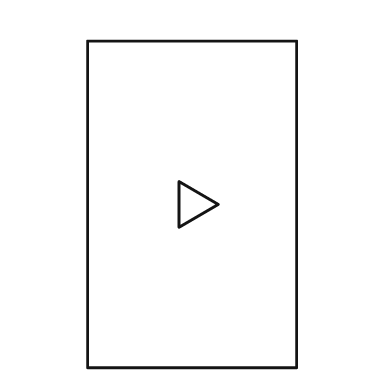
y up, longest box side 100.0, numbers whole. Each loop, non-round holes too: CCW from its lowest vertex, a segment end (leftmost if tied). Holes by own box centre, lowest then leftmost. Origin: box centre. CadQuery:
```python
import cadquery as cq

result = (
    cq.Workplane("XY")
    .moveTo(-32.0, -50.0)
    .lineTo(32.0, -50.0)
    .lineTo(32.0, 50.0)
    .lineTo(-32.0, 50.0)
    .close()
    .moveTo(-4.0, -7.0)
    .lineTo(8.0, 0.0)
    .lineTo(-4.0, 7.0)
    .close()
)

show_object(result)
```